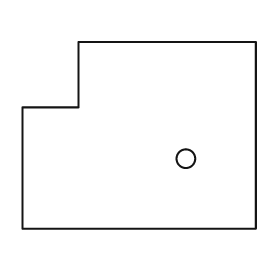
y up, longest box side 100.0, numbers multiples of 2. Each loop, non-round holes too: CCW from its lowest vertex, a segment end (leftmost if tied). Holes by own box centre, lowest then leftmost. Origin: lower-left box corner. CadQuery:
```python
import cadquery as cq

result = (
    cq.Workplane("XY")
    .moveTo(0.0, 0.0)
    .lineTo(100.0, 0.0)
    .lineTo(100.0, 80.0)
    .lineTo(24.0, 80.0)
    .lineTo(24.0, 52.0)
    .lineTo(0.0, 52.0)
    .close()
    .moveTo(70.0, 30.0)
    .circle(4.0)
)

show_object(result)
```